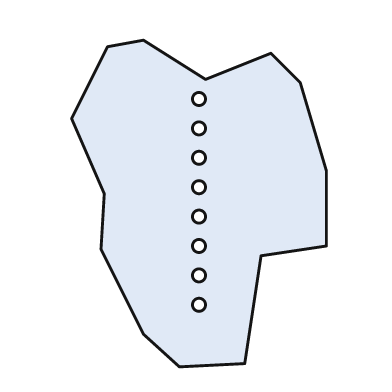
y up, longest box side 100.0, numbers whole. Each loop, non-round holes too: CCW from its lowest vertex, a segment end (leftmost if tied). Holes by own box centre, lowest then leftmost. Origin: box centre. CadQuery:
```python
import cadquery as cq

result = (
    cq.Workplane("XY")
    .moveTo(-6.0, -50.0)
    .lineTo(14.0, -49.0)
    .lineTo(19.0, -16.0)
    .lineTo(39.0, -13.0)
    .lineTo(39.0, 10.0)
    .lineTo(31.0, 37.0)
    .lineTo(22.0, 46.0)
    .lineTo(2.0, 38.0)
    .lineTo(-17.0, 50.0)
    .lineTo(-28.0, 48.0)
    .lineTo(-39.0, 26.0)
    .lineTo(-29.0, 3.0)
    .lineTo(-30.0, -14.0)
    .lineTo(-17.0, -40.0)
    .close()
    .moveTo(0.0, -31.0)
    .circle(2.0)
    .moveTo(0.0, -22.0)
    .circle(2.0)
    .moveTo(0.0, -13.0)
    .circle(2.0)
    .moveTo(0.0, -4.0)
    .circle(2.0)
    .moveTo(0.0, 5.0)
    .circle(2.0)
    .moveTo(0.0, 14.0)
    .circle(2.0)
    .moveTo(0.0, 23.0)
    .circle(2.0)
    .moveTo(0.0, 32.0)
    .circle(2.0)
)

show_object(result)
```